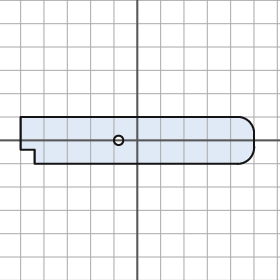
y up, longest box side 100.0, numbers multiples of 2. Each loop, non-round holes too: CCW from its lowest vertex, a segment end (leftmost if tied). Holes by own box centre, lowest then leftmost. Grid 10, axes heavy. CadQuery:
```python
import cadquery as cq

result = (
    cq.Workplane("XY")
    .moveTo(-44.0, -10.0)
    .lineTo(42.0, -10.0)
    .threePointArc((48.0, -8.0), (50.0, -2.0))
    .lineTo(50.0, 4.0)
    .threePointArc((48.0, 8.0), (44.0, 10.0))
    .lineTo(-50.0, 10.0)
    .lineTo(-50.0, -4.0)
    .lineTo(-44.0, -4.0)
    .close()
    .moveTo(-8.0, 0.0)
    .circle(2.0)
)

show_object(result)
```